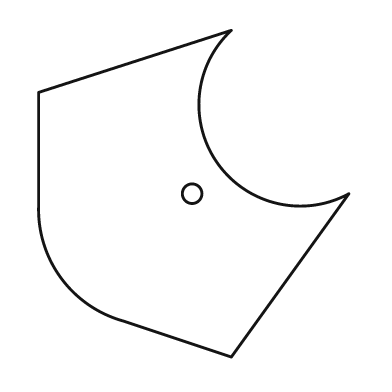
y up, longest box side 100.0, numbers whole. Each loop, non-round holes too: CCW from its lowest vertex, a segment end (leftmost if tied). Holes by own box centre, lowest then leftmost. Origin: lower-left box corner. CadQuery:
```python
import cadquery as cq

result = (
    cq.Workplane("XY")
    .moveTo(59.0, 0.0)
    .lineTo(95.0, 50.0)
    .threePointArc((55.0, 59.0), (59.0, 100.0))
    .lineTo(0.0, 81.0)
    .lineTo(0.0, 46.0)
    .threePointArc((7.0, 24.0), (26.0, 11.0))
    .close()
    .moveTo(47.0, 50.0)
    .circle(3.0)
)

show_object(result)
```